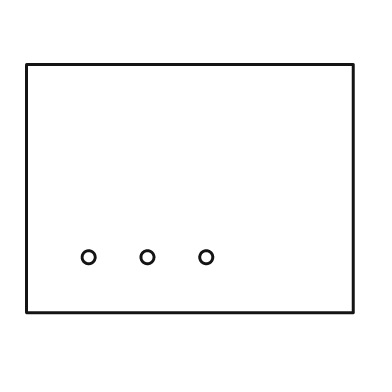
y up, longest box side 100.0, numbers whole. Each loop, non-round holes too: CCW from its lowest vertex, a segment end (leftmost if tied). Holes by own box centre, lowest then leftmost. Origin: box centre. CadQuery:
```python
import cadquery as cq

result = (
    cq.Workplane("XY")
    .moveTo(-50.0, -38.0)
    .lineTo(50.0, -38.0)
    .lineTo(50.0, 38.0)
    .lineTo(-50.0, 38.0)
    .close()
    .moveTo(-31.0, -21.0)
    .circle(2.0)
    .moveTo(-13.0, -21.0)
    .circle(2.0)
    .moveTo(5.0, -21.0)
    .circle(2.0)
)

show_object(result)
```